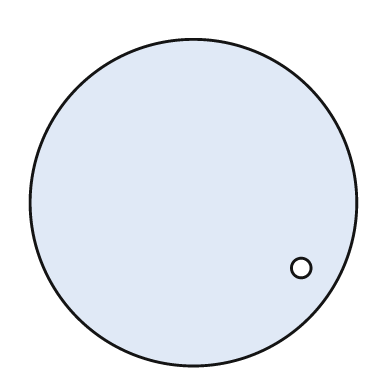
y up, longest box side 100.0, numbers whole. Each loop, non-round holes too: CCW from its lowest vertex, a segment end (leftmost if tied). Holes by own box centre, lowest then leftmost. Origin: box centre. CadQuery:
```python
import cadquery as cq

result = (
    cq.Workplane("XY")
    .moveTo(0.0, 0.0)
    .circle(50.0)
    .moveTo(33.0, -20.0)
    .circle(3.0)
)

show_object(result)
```